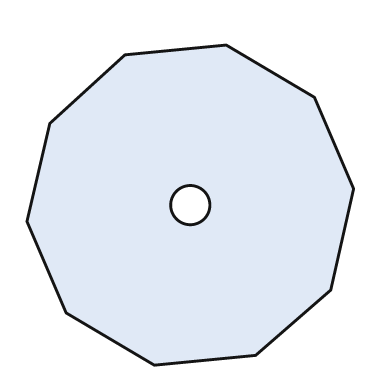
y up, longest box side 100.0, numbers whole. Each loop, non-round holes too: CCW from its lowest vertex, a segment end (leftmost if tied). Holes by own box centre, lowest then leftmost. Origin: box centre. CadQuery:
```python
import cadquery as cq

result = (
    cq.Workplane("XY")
    .moveTo(-11.0, -49.0)
    .lineTo(20.0, -46.0)
    .lineTo(43.0, -26.0)
    .lineTo(50.0, 5.0)
    .lineTo(38.0, 33.0)
    .lineTo(11.0, 49.0)
    .lineTo(-20.0, 46.0)
    .lineTo(-43.0, 25.0)
    .lineTo(-50.0, -5.0)
    .lineTo(-38.0, -33.0)
    .close()
    .moveTo(0.0, 0.0)
    .circle(6.0)
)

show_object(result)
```